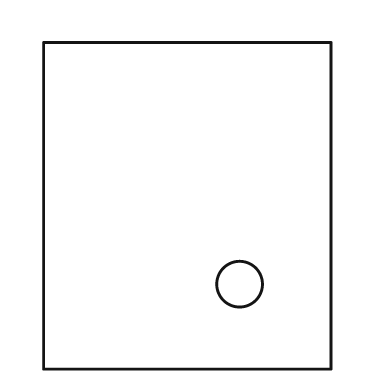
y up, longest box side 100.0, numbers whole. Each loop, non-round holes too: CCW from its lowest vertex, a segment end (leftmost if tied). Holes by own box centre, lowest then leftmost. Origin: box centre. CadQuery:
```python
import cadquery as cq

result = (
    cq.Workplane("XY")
    .moveTo(-44.0, -50.0)
    .lineTo(44.0, -50.0)
    .lineTo(44.0, 50.0)
    .lineTo(-44.0, 50.0)
    .close()
    .moveTo(16.0, -24.0)
    .circle(7.0)
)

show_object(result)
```